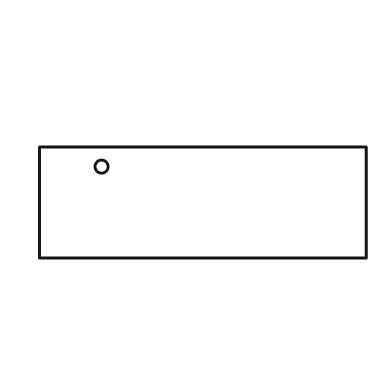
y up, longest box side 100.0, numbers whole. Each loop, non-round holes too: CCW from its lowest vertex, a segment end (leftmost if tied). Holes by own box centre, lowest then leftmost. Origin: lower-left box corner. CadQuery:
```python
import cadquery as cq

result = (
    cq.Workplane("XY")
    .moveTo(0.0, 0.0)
    .lineTo(100.0, 0.0)
    .lineTo(100.0, 34.0)
    .lineTo(0.0, 34.0)
    .close()
    .moveTo(19.0, 28.0)
    .circle(2.0)
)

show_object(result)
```